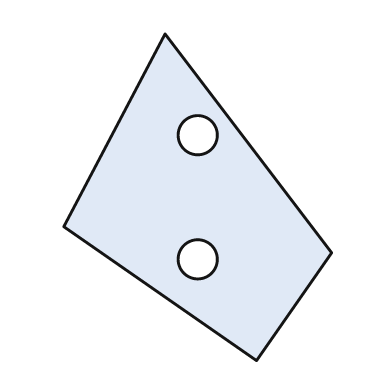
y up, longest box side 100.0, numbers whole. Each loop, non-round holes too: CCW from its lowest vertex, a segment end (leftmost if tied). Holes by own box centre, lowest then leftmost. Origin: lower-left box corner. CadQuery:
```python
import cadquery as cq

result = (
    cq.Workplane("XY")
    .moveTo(59.0, 0.0)
    .lineTo(82.0, 33.0)
    .lineTo(31.0, 100.0)
    .lineTo(0.0, 41.0)
    .close()
    .moveTo(41.0, 31.0)
    .circle(6.0)
    .moveTo(41.0, 69.0)
    .circle(6.0)
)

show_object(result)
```